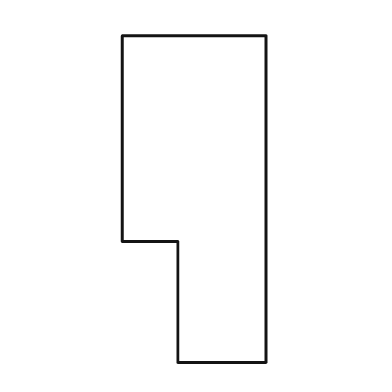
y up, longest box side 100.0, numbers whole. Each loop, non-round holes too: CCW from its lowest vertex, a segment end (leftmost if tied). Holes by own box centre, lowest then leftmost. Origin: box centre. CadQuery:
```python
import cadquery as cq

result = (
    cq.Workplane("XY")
    .moveTo(-5.0, -50.0)
    .lineTo(22.0, -50.0)
    .lineTo(22.0, 50.0)
    .lineTo(-22.0, 50.0)
    .lineTo(-22.0, -13.0)
    .lineTo(-5.0, -13.0)
    .close()
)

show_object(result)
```